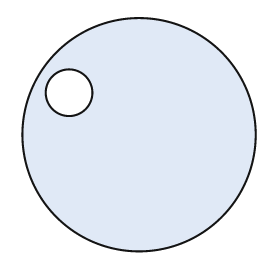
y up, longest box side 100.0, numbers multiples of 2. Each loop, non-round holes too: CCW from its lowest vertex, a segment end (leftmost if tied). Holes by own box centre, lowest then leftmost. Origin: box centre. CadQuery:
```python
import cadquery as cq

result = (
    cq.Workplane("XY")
    .moveTo(0.0, 0.0)
    .circle(50.0)
    .moveTo(-30.0, 18.0)
    .circle(10.0)
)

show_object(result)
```